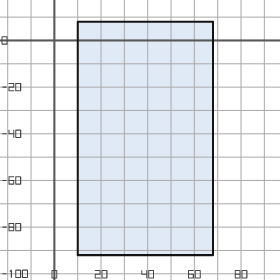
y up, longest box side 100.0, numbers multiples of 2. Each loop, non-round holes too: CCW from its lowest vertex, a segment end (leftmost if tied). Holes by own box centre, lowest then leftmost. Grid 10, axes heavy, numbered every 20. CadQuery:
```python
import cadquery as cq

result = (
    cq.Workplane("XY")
    .moveTo(10.0, -92.0)
    .lineTo(68.0, -92.0)
    .lineTo(68.0, 8.0)
    .lineTo(10.0, 8.0)
    .close()
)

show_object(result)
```